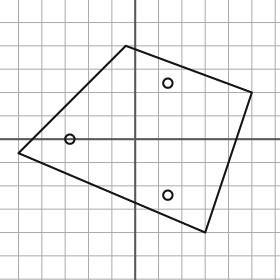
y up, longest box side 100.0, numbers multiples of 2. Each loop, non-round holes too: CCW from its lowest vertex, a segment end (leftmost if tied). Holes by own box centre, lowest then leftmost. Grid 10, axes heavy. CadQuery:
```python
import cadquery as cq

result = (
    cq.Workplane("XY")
    .moveTo(30.0, -40.0)
    .lineTo(50.0, 20.0)
    .lineTo(-4.0, 40.0)
    .lineTo(-50.0, -6.0)
    .close()
    .moveTo(14.0, -24.0)
    .circle(2.0)
    .moveTo(-28.0, 0.0)
    .circle(2.0)
    .moveTo(14.0, 24.0)
    .circle(2.0)
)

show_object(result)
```